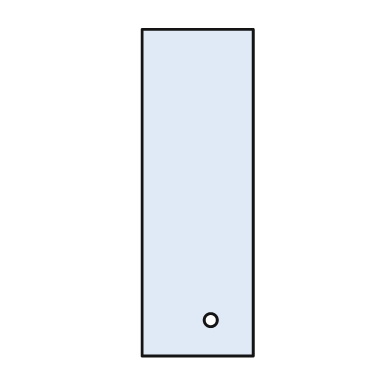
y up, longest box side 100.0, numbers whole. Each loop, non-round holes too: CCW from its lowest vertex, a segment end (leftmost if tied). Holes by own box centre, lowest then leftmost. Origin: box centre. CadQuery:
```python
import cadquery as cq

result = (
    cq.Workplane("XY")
    .moveTo(-17.0, -50.0)
    .lineTo(17.0, -50.0)
    .lineTo(17.0, 50.0)
    .lineTo(-17.0, 50.0)
    .close()
    .moveTo(4.0, -39.0)
    .circle(2.0)
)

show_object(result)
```